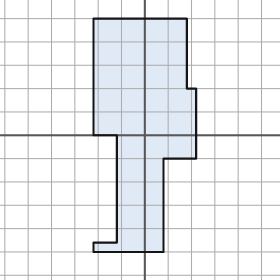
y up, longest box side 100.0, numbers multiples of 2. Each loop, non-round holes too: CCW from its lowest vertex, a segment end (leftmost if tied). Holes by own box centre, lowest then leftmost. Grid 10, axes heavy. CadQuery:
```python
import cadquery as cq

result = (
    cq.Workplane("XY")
    .moveTo(-22.0, -50.0)
    .lineTo(8.0, -50.0)
    .lineTo(8.0, -10.0)
    .lineTo(22.0, -10.0)
    .lineTo(22.0, 20.0)
    .lineTo(18.0, 20.0)
    .lineTo(18.0, 50.0)
    .lineTo(-22.0, 50.0)
    .lineTo(-22.0, 0.0)
    .lineTo(-12.0, 0.0)
    .lineTo(-12.0, -46.0)
    .lineTo(-22.0, -46.0)
    .close()
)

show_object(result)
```